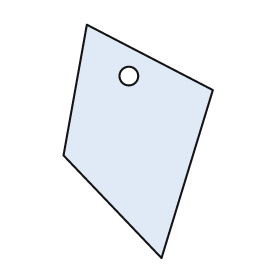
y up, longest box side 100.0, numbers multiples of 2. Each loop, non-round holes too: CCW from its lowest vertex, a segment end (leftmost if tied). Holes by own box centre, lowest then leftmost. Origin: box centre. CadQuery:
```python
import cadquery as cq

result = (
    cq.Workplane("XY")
    .moveTo(10.0, -50.0)
    .lineTo(32.0, 22.0)
    .lineTo(-22.0, 50.0)
    .lineTo(-32.0, -6.0)
    .close()
    .moveTo(-4.0, 28.0)
    .circle(4.0)
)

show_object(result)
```